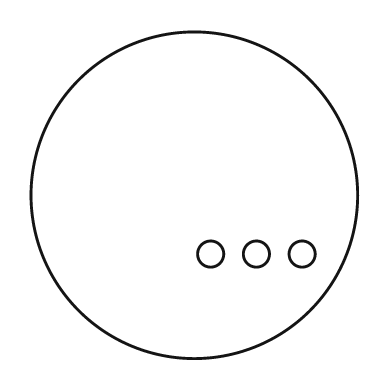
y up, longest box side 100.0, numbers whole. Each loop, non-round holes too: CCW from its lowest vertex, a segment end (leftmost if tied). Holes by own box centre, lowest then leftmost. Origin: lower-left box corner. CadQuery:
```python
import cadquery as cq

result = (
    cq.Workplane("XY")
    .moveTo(50.0, 50.0)
    .circle(50.0)
    .moveTo(55.0, 32.0)
    .circle(4.0)
    .moveTo(69.0, 32.0)
    .circle(4.0)
    .moveTo(83.0, 32.0)
    .circle(4.0)
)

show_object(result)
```